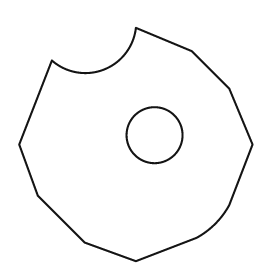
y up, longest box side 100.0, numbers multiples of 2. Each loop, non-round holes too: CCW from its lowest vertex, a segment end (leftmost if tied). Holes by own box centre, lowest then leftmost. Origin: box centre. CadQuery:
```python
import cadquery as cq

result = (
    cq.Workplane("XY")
    .moveTo(0.0, -50.0)
    .lineTo(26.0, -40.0)
    .threePointArc((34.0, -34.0), (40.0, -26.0))
    .lineTo(50.0, 0.0)
    .lineTo(40.0, 24.0)
    .lineTo(24.0, 40.0)
    .lineTo(0.0, 50.0)
    .threePointArc((-14.0, 32.0), (-36.0, 36.0))
    .lineTo(-50.0, 0.0)
    .lineTo(-42.0, -22.0)
    .lineTo(-22.0, -42.0)
    .close()
    .moveTo(8.0, 4.0)
    .circle(12.0)
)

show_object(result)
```